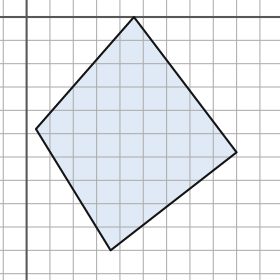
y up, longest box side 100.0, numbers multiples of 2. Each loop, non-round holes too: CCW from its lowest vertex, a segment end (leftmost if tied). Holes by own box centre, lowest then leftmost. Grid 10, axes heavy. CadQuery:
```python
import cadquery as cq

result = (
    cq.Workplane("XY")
    .moveTo(36.0, -100.0)
    .lineTo(90.0, -58.0)
    .lineTo(46.0, 0.0)
    .lineTo(4.0, -48.0)
    .close()
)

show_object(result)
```